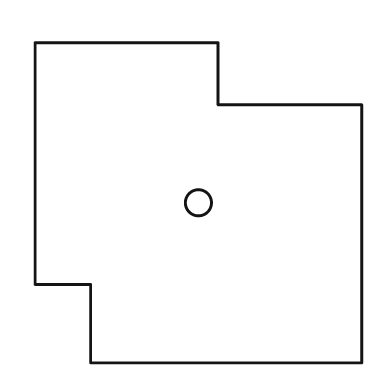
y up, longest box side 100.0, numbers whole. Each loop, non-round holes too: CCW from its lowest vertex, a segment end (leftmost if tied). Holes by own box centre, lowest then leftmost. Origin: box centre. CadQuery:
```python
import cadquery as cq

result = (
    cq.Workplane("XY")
    .moveTo(-33.0, -49.0)
    .lineTo(50.0, -49.0)
    .lineTo(50.0, 30.0)
    .lineTo(6.0, 30.0)
    .lineTo(6.0, 49.0)
    .lineTo(-50.0, 49.0)
    .lineTo(-50.0, -25.0)
    .lineTo(-33.0, -25.0)
    .close()
    .moveTo(0.0, 0.0)
    .circle(4.0)
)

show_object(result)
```